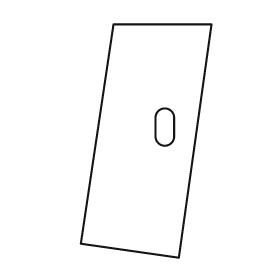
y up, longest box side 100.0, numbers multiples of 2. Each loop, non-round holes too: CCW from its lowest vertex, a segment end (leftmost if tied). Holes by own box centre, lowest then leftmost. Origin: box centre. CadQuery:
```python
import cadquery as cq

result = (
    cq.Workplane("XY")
    .moveTo(14.0, -50.0)
    .lineTo(28.0, 50.0)
    .lineTo(-14.0, 50.0)
    .lineTo(-28.0, -44.0)
    .close()
    .moveTo(4.0, 2.0)
    .threePointArc((8.0, -2.0), (12.0, 2.0))
    .lineTo(12.0, 10.0)
    .threePointArc((8.0, 14.0), (4.0, 10.0))
    .close()
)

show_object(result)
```